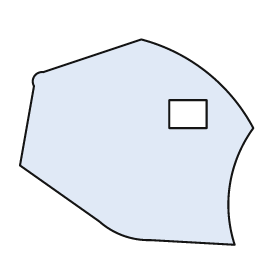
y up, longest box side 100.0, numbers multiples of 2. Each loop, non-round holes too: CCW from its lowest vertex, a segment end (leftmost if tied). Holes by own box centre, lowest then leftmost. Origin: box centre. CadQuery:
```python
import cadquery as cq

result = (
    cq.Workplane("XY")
    .moveTo(42.0, -44.0)
    .threePointArc((40.0, -18.0), (50.0, 6.0))
    .threePointArc((30.0, 30.0), (2.0, 44.0))
    .lineTo(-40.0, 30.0)
    .threePointArc((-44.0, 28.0), (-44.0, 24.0))
    .lineTo(-50.0, -10.0)
    .lineTo(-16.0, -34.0)
    .threePointArc((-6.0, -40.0), (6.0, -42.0))
    .close()
    .moveTo(14.0, 6.0)
    .lineTo(30.0, 6.0)
    .lineTo(30.0, 18.0)
    .lineTo(14.0, 18.0)
    .close()
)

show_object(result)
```